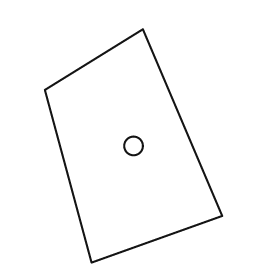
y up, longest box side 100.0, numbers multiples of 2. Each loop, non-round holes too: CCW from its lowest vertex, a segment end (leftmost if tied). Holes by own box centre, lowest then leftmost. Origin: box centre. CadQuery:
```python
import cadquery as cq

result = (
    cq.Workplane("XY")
    .moveTo(-18.0, -50.0)
    .lineTo(38.0, -30.0)
    .lineTo(4.0, 50.0)
    .lineTo(-38.0, 24.0)
    .close()
    .moveTo(0.0, 0.0)
    .circle(4.0)
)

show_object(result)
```